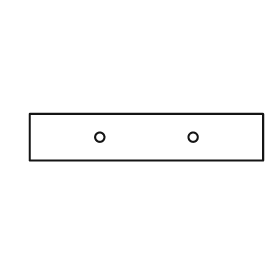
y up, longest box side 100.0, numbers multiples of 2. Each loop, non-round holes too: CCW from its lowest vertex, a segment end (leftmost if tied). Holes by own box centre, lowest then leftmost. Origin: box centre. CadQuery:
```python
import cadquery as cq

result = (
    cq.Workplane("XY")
    .moveTo(-50.0, -10.0)
    .lineTo(50.0, -10.0)
    .lineTo(50.0, 10.0)
    .lineTo(-50.0, 10.0)
    .close()
    .moveTo(-20.0, 0.0)
    .circle(2.0)
    .moveTo(20.0, 0.0)
    .circle(2.0)
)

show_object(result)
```